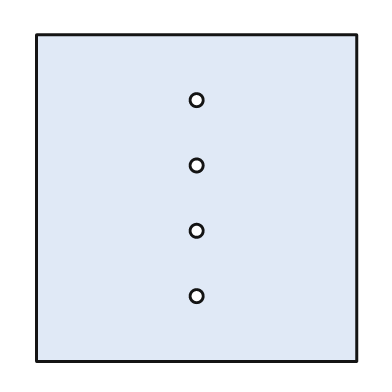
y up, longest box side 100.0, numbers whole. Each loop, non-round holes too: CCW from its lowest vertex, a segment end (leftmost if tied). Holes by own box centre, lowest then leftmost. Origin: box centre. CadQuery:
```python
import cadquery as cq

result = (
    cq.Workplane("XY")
    .moveTo(-49.0, -50.0)
    .lineTo(49.0, -50.0)
    .lineTo(49.0, 50.0)
    .lineTo(-49.0, 50.0)
    .close()
    .moveTo(0.0, -30.0)
    .circle(2.0)
    .moveTo(0.0, -10.0)
    .circle(2.0)
    .moveTo(0.0, 10.0)
    .circle(2.0)
    .moveTo(0.0, 30.0)
    .circle(2.0)
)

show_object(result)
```